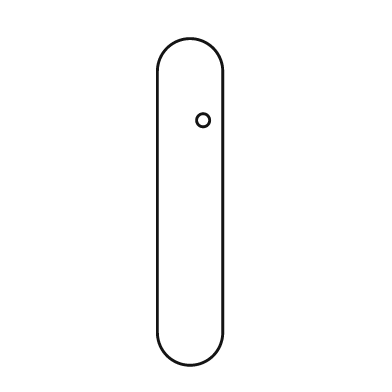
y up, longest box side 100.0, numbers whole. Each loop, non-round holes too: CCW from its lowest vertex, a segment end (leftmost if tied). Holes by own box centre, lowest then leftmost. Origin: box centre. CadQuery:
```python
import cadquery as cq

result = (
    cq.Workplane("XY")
    .moveTo(-10.0, -40.0)
    .threePointArc((0.0, -50.0), (10.0, -40.0))
    .lineTo(10.0, 40.0)
    .threePointArc((0.0, 50.0), (-10.0, 40.0))
    .close()
    .moveTo(4.0, 25.0)
    .circle(2.0)
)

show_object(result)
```